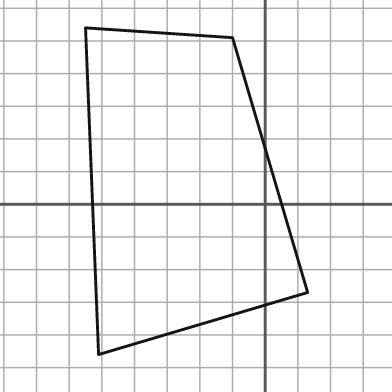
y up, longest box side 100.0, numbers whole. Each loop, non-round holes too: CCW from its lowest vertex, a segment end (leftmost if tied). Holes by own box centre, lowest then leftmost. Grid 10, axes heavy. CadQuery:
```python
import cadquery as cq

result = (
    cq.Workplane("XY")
    .moveTo(-51.0, -46.0)
    .lineTo(13.0, -27.0)
    .lineTo(-10.0, 51.0)
    .lineTo(-55.0, 54.0)
    .close()
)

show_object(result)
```